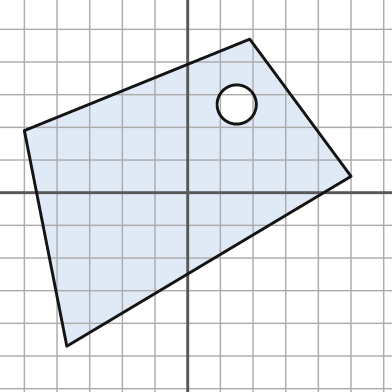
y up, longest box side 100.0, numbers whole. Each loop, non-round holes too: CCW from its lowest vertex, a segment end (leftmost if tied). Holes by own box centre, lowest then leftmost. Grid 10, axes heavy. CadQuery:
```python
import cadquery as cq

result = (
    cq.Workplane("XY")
    .moveTo(-37.0, -47.0)
    .lineTo(50.0, 5.0)
    .lineTo(19.0, 47.0)
    .lineTo(-50.0, 19.0)
    .close()
    .moveTo(15.0, 27.0)
    .circle(6.0)
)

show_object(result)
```